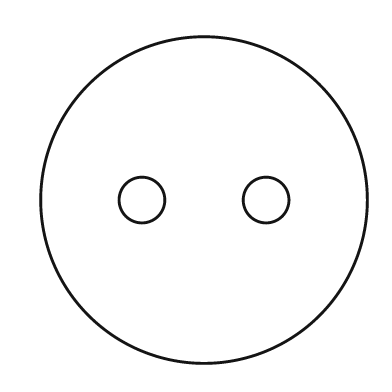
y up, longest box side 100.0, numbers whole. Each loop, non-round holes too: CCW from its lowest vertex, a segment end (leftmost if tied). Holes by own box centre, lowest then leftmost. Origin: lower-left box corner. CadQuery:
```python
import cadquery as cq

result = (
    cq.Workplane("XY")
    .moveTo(50.0, 50.0)
    .circle(50.0)
    .moveTo(31.0, 50.0)
    .circle(7.0)
    .moveTo(69.0, 50.0)
    .circle(7.0)
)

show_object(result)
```